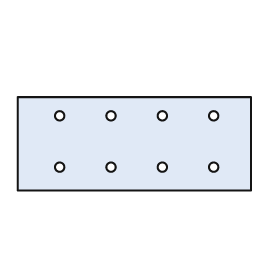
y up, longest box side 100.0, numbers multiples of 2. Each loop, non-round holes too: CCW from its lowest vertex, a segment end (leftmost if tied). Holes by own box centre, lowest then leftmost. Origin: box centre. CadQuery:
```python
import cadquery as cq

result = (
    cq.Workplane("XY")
    .moveTo(-50.0, -20.0)
    .lineTo(50.0, -20.0)
    .lineTo(50.0, 20.0)
    .lineTo(-50.0, 20.0)
    .close()
    .moveTo(-32.0, -10.0)
    .circle(2.0)
    .moveTo(-10.0, -10.0)
    .circle(2.0)
    .moveTo(12.0, -10.0)
    .circle(2.0)
    .moveTo(34.0, -10.0)
    .circle(2.0)
    .moveTo(-32.0, 12.0)
    .circle(2.0)
    .moveTo(-10.0, 12.0)
    .circle(2.0)
    .moveTo(12.0, 12.0)
    .circle(2.0)
    .moveTo(34.0, 12.0)
    .circle(2.0)
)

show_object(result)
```